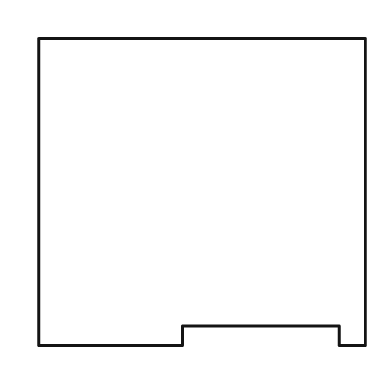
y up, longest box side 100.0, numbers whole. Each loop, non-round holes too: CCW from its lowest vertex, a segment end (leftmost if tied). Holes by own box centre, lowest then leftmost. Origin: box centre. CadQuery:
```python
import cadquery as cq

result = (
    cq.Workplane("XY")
    .moveTo(-50.0, -47.0)
    .lineTo(-6.0, -47.0)
    .lineTo(-6.0, -41.0)
    .lineTo(42.0, -41.0)
    .lineTo(42.0, -47.0)
    .lineTo(50.0, -47.0)
    .lineTo(50.0, 47.0)
    .lineTo(-50.0, 47.0)
    .close()
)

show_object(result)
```